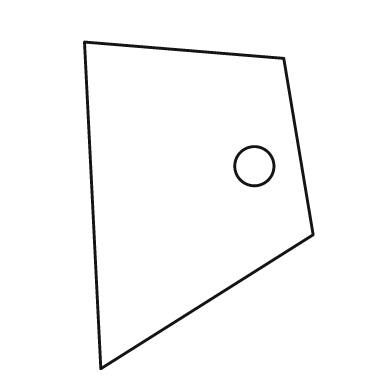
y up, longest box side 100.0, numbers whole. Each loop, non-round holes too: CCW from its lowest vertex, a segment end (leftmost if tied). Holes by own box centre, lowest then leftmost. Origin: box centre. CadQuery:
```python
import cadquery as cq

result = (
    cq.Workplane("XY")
    .moveTo(-30.0, -50.0)
    .lineTo(35.0, -9.0)
    .lineTo(26.0, 45.0)
    .lineTo(-35.0, 50.0)
    .close()
    .moveTo(17.0, 12.0)
    .circle(6.0)
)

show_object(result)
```